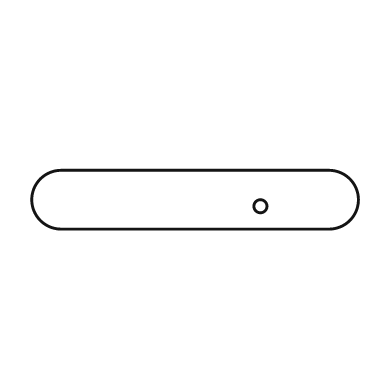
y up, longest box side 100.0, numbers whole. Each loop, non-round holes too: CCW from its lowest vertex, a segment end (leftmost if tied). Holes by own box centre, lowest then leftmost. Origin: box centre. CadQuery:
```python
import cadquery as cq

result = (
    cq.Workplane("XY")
    .moveTo(-41.0, -9.0)
    .lineTo(41.0, -9.0)
    .threePointArc((50.0, 0.0), (41.0, 9.0))
    .lineTo(-41.0, 9.0)
    .threePointArc((-50.0, 0.0), (-41.0, -9.0))
    .close()
    .moveTo(20.0, -2.0)
    .circle(2.0)
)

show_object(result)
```